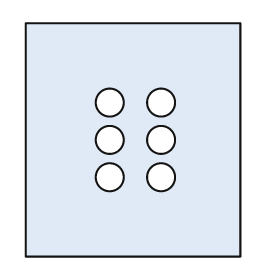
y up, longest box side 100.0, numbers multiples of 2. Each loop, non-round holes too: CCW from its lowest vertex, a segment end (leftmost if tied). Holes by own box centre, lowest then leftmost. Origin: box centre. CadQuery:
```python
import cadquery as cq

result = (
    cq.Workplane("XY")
    .moveTo(-46.0, -50.0)
    .lineTo(46.0, -50.0)
    .lineTo(46.0, 50.0)
    .lineTo(-46.0, 50.0)
    .close()
    .moveTo(-10.0, -16.0)
    .circle(6.0)
    .moveTo(12.0, -16.0)
    .circle(6.0)
    .moveTo(-10.0, 0.0)
    .circle(6.0)
    .moveTo(12.0, 0.0)
    .circle(6.0)
    .moveTo(-10.0, 16.0)
    .circle(6.0)
    .moveTo(12.0, 16.0)
    .circle(6.0)
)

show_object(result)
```